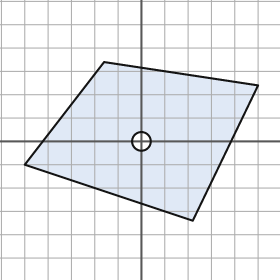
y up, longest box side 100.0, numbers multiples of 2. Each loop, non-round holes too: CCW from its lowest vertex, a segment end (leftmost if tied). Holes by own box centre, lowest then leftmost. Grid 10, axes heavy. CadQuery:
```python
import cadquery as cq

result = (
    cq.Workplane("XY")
    .moveTo(22.0, -34.0)
    .lineTo(50.0, 24.0)
    .lineTo(-16.0, 34.0)
    .lineTo(-50.0, -10.0)
    .close()
    .moveTo(0.0, 0.0)
    .circle(4.0)
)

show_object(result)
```